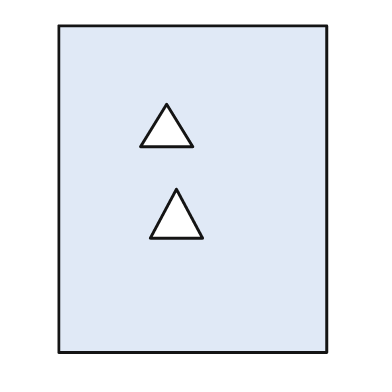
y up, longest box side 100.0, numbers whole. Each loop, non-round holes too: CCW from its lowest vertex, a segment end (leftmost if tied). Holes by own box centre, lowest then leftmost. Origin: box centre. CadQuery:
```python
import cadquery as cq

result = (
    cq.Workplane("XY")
    .moveTo(-41.0, -50.0)
    .lineTo(41.0, -50.0)
    .lineTo(41.0, 50.0)
    .lineTo(-41.0, 50.0)
    .close()
    .moveTo(-13.0, -15.0)
    .lineTo(3.0, -15.0)
    .lineTo(-5.0, 0.0)
    .close()
    .moveTo(-16.0, 13.0)
    .lineTo(0.0, 13.0)
    .lineTo(-8.0, 26.0)
    .close()
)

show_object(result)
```